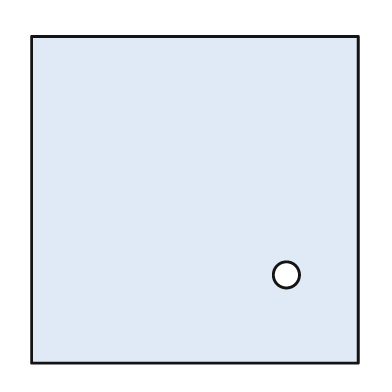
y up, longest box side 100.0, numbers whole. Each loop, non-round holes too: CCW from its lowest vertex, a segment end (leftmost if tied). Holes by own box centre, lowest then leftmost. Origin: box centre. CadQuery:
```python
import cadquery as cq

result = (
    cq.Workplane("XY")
    .moveTo(-50.0, -50.0)
    .lineTo(50.0, -50.0)
    .lineTo(50.0, 50.0)
    .lineTo(-50.0, 50.0)
    .close()
    .moveTo(28.0, -23.0)
    .circle(4.0)
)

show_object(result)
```